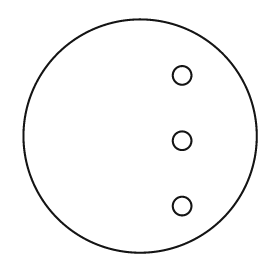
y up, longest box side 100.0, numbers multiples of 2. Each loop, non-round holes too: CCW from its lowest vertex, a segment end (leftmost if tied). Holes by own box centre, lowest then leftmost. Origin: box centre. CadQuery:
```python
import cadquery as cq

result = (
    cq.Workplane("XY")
    .moveTo(0.0, 0.0)
    .circle(50.0)
    .moveTo(18.0, -30.0)
    .circle(4.0)
    .moveTo(18.0, -2.0)
    .circle(4.0)
    .moveTo(18.0, 26.0)
    .circle(4.0)
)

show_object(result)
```